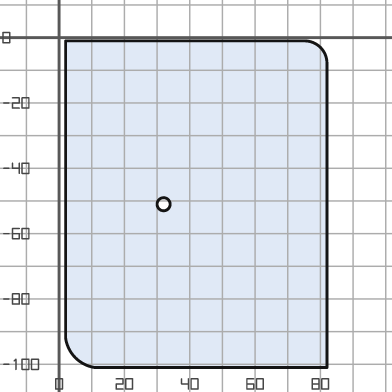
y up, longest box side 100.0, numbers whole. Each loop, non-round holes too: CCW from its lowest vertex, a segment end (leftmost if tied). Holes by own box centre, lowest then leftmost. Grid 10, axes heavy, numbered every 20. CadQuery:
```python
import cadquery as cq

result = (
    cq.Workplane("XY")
    .moveTo(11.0, -101.0)
    .lineTo(82.0, -101.0)
    .lineTo(82.0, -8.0)
    .threePointArc((80.0, -3.0), (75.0, -1.0))
    .lineTo(2.0, -1.0)
    .lineTo(2.0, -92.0)
    .threePointArc((5.0, -98.0), (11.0, -101.0))
    .close()
    .moveTo(32.0, -51.0)
    .circle(2.0)
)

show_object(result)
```